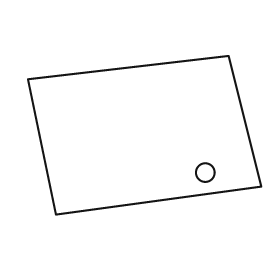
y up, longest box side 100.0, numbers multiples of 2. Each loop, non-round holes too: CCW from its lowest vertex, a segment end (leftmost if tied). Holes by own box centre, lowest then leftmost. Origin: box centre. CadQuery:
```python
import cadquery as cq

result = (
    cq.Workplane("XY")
    .moveTo(-38.0, -34.0)
    .lineTo(50.0, -22.0)
    .lineTo(36.0, 34.0)
    .lineTo(-50.0, 24.0)
    .close()
    .moveTo(26.0, -16.0)
    .circle(4.0)
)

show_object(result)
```